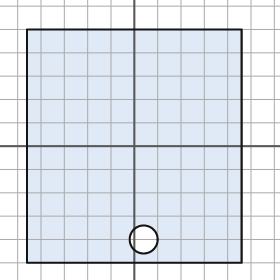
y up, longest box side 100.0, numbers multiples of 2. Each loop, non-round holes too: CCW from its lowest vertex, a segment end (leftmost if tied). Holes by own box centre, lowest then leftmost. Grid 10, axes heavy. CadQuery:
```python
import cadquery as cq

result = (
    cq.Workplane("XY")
    .moveTo(-46.0, -50.0)
    .lineTo(46.0, -50.0)
    .lineTo(46.0, 50.0)
    .lineTo(-46.0, 50.0)
    .close()
    .moveTo(4.0, -40.0)
    .circle(6.0)
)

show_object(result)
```